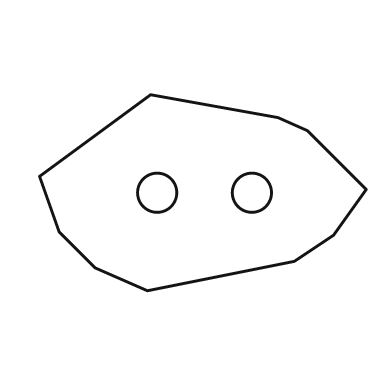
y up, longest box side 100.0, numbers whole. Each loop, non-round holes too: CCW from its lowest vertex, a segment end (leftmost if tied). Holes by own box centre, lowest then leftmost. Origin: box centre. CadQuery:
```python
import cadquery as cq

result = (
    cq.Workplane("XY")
    .moveTo(-17.0, -30.0)
    .lineTo(28.0, -21.0)
    .lineTo(40.0, -13.0)
    .lineTo(50.0, 1.0)
    .lineTo(32.0, 19.0)
    .lineTo(23.0, 23.0)
    .lineTo(-16.0, 30.0)
    .lineTo(-50.0, 5.0)
    .lineTo(-44.0, -12.0)
    .lineTo(-33.0, -23.0)
    .close()
    .moveTo(-14.0, 0.0)
    .circle(6.0)
    .moveTo(15.0, 0.0)
    .circle(6.0)
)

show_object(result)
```